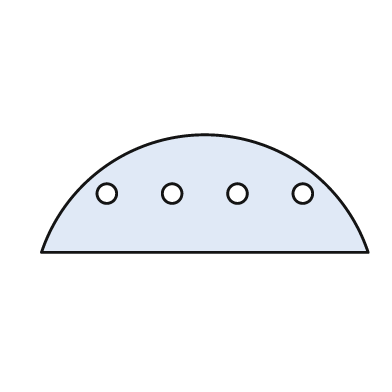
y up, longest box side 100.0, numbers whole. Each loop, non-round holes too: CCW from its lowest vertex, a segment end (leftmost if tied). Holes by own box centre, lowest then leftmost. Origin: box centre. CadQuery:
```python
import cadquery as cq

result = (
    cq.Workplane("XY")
    .moveTo(-50.0, -18.0)
    .lineTo(50.0, -18.0)
    .threePointArc((0.0, 18.0), (-50.0, -18.0))
    .close()
    .moveTo(-30.0, 0.0)
    .circle(3.0)
    .moveTo(-10.0, 0.0)
    .circle(3.0)
    .moveTo(10.0, 0.0)
    .circle(3.0)
    .moveTo(30.0, 0.0)
    .circle(3.0)
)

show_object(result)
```